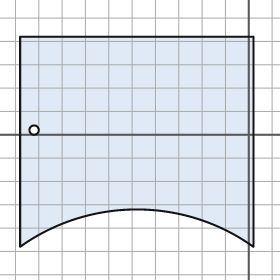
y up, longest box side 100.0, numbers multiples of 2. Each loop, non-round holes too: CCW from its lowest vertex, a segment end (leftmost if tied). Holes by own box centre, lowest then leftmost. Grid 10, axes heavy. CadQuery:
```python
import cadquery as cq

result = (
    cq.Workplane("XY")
    .moveTo(-98.0, -48.0)
    .threePointArc((-48.0, -32.0), (2.0, -48.0))
    .lineTo(2.0, 42.0)
    .lineTo(-98.0, 42.0)
    .close()
    .moveTo(-92.0, 2.0)
    .circle(2.0)
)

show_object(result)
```